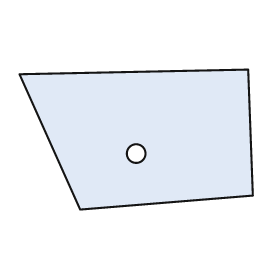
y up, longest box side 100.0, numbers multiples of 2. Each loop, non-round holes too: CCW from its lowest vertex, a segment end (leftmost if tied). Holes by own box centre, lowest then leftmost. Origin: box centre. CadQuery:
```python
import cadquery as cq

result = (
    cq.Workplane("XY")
    .moveTo(-24.0, -30.0)
    .lineTo(50.0, -24.0)
    .lineTo(48.0, 30.0)
    .lineTo(-50.0, 28.0)
    .close()
    .moveTo(0.0, -6.0)
    .circle(4.0)
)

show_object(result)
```